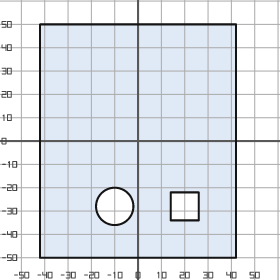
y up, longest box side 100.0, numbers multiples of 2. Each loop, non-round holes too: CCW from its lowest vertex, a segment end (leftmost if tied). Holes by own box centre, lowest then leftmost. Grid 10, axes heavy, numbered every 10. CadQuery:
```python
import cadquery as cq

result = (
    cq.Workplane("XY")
    .moveTo(-42.0, -50.0)
    .lineTo(42.0, -50.0)
    .lineTo(42.0, 50.0)
    .lineTo(-42.0, 50.0)
    .close()
    .moveTo(-10.0, -28.0)
    .circle(8.0)
    .moveTo(14.0, -34.0)
    .lineTo(26.0, -34.0)
    .lineTo(26.0, -22.0)
    .lineTo(14.0, -22.0)
    .close()
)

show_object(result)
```